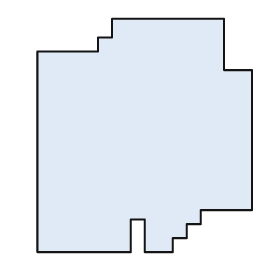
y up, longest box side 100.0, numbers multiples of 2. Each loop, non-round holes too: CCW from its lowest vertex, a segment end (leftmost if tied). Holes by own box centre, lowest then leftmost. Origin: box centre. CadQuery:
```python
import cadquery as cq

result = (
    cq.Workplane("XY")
    .moveTo(-46.0, -50.0)
    .lineTo(-6.0, -50.0)
    .lineTo(-6.0, -36.0)
    .lineTo(0.0, -36.0)
    .lineTo(0.0, -50.0)
    .lineTo(12.0, -50.0)
    .lineTo(12.0, -44.0)
    .lineTo(18.0, -44.0)
    .lineTo(18.0, -38.0)
    .lineTo(24.0, -38.0)
    .lineTo(24.0, -32.0)
    .lineTo(46.0, -32.0)
    .lineTo(46.0, 28.0)
    .lineTo(34.0, 28.0)
    .lineTo(34.0, 50.0)
    .lineTo(-14.0, 50.0)
    .lineTo(-14.0, 42.0)
    .lineTo(-20.0, 42.0)
    .lineTo(-20.0, 36.0)
    .lineTo(-46.0, 36.0)
    .close()
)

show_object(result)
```